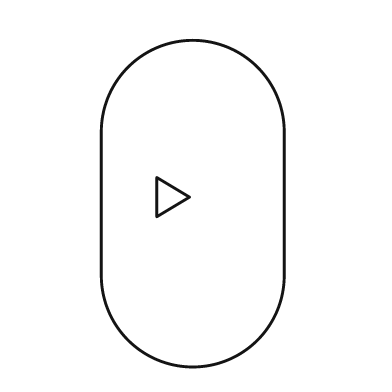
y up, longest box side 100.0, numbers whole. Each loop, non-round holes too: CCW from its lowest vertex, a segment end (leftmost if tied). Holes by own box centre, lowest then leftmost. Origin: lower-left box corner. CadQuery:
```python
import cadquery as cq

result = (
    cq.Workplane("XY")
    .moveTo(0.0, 28.0)
    .threePointArc((28.0, 0.0), (56.0, 28.0))
    .lineTo(56.0, 72.0)
    .threePointArc((28.0, 100.0), (0.0, 72.0))
    .close()
    .moveTo(17.0, 46.0)
    .lineTo(27.0, 52.0)
    .lineTo(17.0, 58.0)
    .close()
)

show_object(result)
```